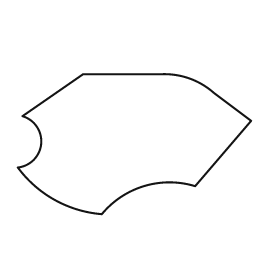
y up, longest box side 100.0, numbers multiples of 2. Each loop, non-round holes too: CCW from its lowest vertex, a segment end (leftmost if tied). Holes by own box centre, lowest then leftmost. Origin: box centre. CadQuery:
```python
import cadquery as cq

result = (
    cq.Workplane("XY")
    .moveTo(-14.0, -30.0)
    .threePointArc((4.0, -18.0), (26.0, -18.0))
    .lineTo(50.0, 10.0)
    .lineTo(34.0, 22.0)
    .threePointArc((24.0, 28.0), (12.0, 30.0))
    .lineTo(-22.0, 30.0)
    .lineTo(-48.0, 12.0)
    .threePointArc((-40.0, 0.0), (-50.0, -10.0))
    .threePointArc((-34.0, -24.0), (-14.0, -30.0))
    .close()
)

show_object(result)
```